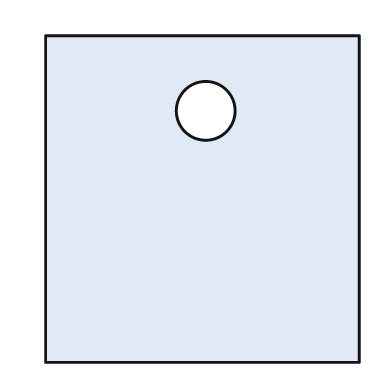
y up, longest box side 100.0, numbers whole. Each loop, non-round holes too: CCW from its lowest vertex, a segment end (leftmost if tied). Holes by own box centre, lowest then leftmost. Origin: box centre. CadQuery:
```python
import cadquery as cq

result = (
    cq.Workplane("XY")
    .moveTo(-48.0, -50.0)
    .lineTo(48.0, -50.0)
    .lineTo(48.0, 50.0)
    .lineTo(-48.0, 50.0)
    .close()
    .moveTo(1.0, 27.0)
    .circle(9.0)
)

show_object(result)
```